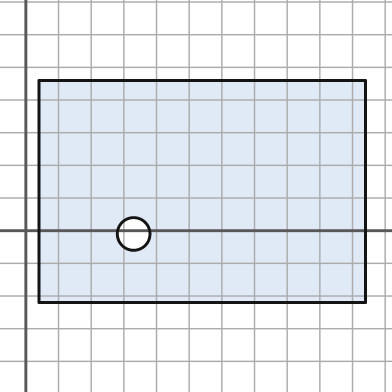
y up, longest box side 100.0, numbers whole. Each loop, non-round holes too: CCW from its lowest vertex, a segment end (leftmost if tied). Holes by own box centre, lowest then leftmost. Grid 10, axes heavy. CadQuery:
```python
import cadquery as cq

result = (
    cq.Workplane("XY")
    .moveTo(4.0, -22.0)
    .lineTo(104.0, -22.0)
    .lineTo(104.0, 46.0)
    .lineTo(4.0, 46.0)
    .close()
    .moveTo(33.0, -1.0)
    .circle(5.0)
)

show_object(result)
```